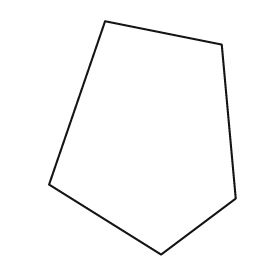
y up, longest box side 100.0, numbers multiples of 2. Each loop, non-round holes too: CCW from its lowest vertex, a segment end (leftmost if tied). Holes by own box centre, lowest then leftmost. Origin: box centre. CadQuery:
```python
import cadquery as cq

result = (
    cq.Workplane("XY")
    .moveTo(8.0, -50.0)
    .lineTo(40.0, -26.0)
    .lineTo(34.0, 40.0)
    .lineTo(-16.0, 50.0)
    .lineTo(-40.0, -20.0)
    .close()
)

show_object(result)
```